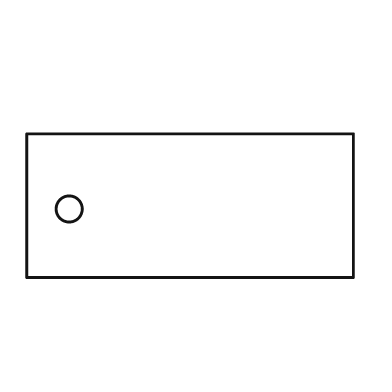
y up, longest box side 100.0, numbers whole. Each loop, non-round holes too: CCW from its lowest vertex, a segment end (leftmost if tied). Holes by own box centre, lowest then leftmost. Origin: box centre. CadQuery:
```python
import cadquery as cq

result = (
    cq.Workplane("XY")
    .moveTo(-50.0, -22.0)
    .lineTo(50.0, -22.0)
    .lineTo(50.0, 22.0)
    .lineTo(-50.0, 22.0)
    .close()
    .moveTo(-37.0, -1.0)
    .circle(4.0)
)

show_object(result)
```